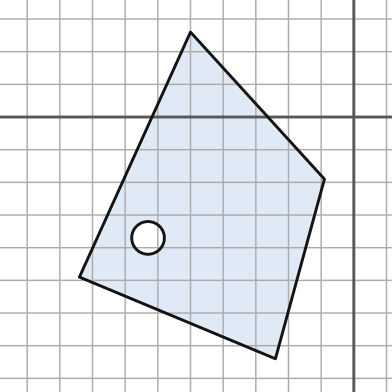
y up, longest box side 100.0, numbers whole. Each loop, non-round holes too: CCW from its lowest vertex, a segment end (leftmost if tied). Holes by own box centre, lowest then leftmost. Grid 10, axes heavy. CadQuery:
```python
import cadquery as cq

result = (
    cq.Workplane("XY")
    .moveTo(-24.0, -74.0)
    .lineTo(-9.0, -19.0)
    .lineTo(-50.0, 26.0)
    .lineTo(-84.0, -49.0)
    .close()
    .moveTo(-63.0, -37.0)
    .circle(5.0)
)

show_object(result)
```